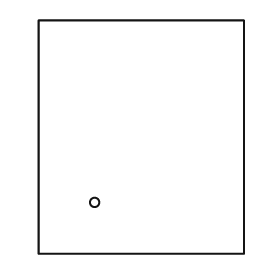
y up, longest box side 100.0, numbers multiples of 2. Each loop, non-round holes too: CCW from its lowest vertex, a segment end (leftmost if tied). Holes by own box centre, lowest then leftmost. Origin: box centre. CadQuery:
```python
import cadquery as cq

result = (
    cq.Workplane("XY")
    .moveTo(-44.0, -50.0)
    .lineTo(44.0, -50.0)
    .lineTo(44.0, 50.0)
    .lineTo(-44.0, 50.0)
    .close()
    .moveTo(-20.0, -28.0)
    .circle(2.0)
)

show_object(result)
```